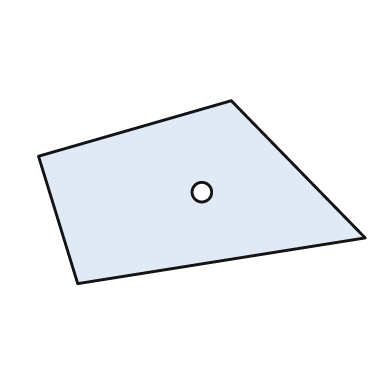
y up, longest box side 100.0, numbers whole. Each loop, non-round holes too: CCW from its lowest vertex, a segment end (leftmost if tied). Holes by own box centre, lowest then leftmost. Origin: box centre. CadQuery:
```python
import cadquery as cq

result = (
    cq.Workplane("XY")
    .moveTo(-38.0, -28.0)
    .lineTo(50.0, -14.0)
    .lineTo(9.0, 28.0)
    .lineTo(-50.0, 11.0)
    .close()
    .moveTo(0.0, 0.0)
    .circle(3.0)
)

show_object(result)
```